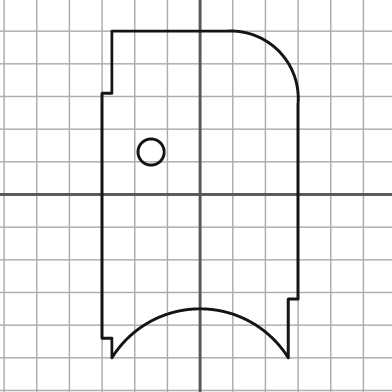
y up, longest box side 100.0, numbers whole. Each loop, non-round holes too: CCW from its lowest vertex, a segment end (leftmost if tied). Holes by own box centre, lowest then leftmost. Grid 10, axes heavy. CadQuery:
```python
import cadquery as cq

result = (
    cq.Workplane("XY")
    .moveTo(-27.0, -50.0)
    .threePointArc((0.0, -35.0), (27.0, -50.0))
    .lineTo(27.0, -32.0)
    .lineTo(30.0, -32.0)
    .lineTo(30.0, 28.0)
    .threePointArc((24.0, 44.0), (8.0, 50.0))
    .lineTo(-27.0, 50.0)
    .lineTo(-27.0, 31.0)
    .lineTo(-30.0, 31.0)
    .lineTo(-30.0, -44.0)
    .lineTo(-27.0, -44.0)
    .close()
    .moveTo(-15.0, 13.0)
    .circle(4.0)
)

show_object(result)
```